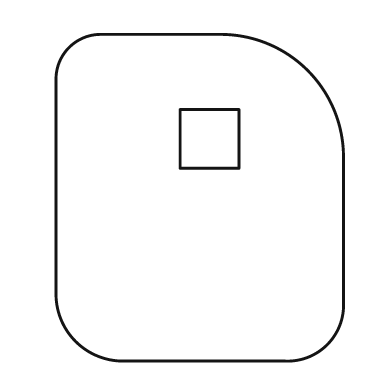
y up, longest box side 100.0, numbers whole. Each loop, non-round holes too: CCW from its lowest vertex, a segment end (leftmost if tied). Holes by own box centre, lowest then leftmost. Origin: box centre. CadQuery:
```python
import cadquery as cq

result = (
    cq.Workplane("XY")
    .moveTo(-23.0, -50.0)
    .lineTo(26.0, -50.0)
    .threePointArc((39.0, -45.0), (44.0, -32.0))
    .lineTo(44.0, 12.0)
    .threePointArc((33.0, 39.0), (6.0, 50.0))
    .lineTo(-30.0, 50.0)
    .threePointArc((-40.0, 46.0), (-44.0, 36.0))
    .lineTo(-44.0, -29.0)
    .threePointArc((-38.0, -44.0), (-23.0, -50.0))
    .close()
    .moveTo(-6.0, 9.0)
    .lineTo(12.0, 9.0)
    .lineTo(12.0, 27.0)
    .lineTo(-6.0, 27.0)
    .close()
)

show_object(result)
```